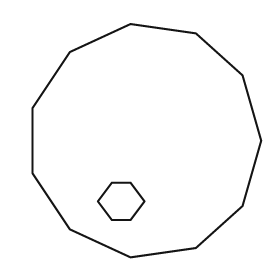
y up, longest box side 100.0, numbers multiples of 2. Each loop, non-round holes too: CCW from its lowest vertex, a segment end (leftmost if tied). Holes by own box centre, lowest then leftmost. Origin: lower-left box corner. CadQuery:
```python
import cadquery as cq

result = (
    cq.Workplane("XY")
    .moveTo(42.0, 0.0)
    .lineTo(70.0, 4.0)
    .lineTo(90.0, 22.0)
    .lineTo(98.0, 50.0)
    .lineTo(90.0, 78.0)
    .lineTo(70.0, 96.0)
    .lineTo(42.0, 100.0)
    .lineTo(16.0, 88.0)
    .lineTo(0.0, 64.0)
    .lineTo(0.0, 36.0)
    .lineTo(16.0, 12.0)
    .close()
    .moveTo(34.0, 16.0)
    .lineTo(42.0, 16.0)
    .lineTo(48.0, 24.0)
    .lineTo(42.0, 32.0)
    .lineTo(34.0, 32.0)
    .lineTo(28.0, 24.0)
    .close()
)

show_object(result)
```